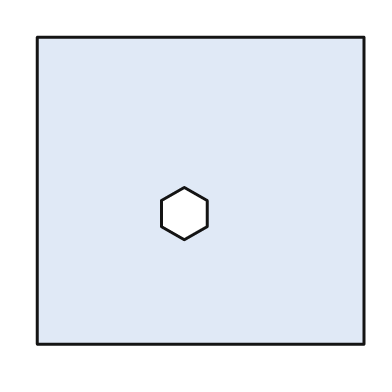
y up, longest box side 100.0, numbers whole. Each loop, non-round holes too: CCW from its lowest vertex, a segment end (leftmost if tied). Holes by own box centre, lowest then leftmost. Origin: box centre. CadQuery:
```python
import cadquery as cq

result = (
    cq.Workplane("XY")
    .moveTo(-50.0, -47.0)
    .lineTo(50.0, -47.0)
    .lineTo(50.0, 47.0)
    .lineTo(-50.0, 47.0)
    .close()
    .moveTo(-5.0, -15.0)
    .lineTo(2.0, -11.0)
    .lineTo(2.0, -3.0)
    .lineTo(-5.0, 1.0)
    .lineTo(-12.0, -3.0)
    .lineTo(-12.0, -11.0)
    .close()
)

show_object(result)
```